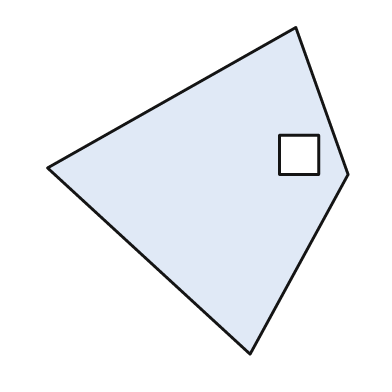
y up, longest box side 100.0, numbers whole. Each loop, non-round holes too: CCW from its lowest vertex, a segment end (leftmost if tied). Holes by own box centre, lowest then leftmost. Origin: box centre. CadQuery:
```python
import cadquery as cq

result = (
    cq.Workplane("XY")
    .moveTo(16.0, -50.0)
    .lineTo(46.0, 5.0)
    .lineTo(30.0, 50.0)
    .lineTo(-46.0, 7.0)
    .close()
    .moveTo(25.0, 5.0)
    .lineTo(37.0, 5.0)
    .lineTo(37.0, 17.0)
    .lineTo(25.0, 17.0)
    .close()
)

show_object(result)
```